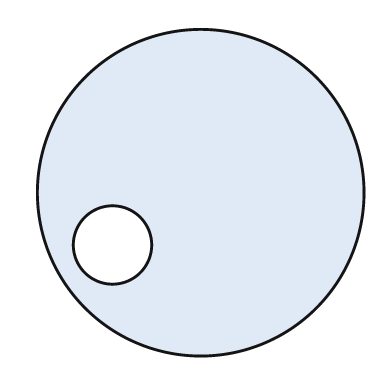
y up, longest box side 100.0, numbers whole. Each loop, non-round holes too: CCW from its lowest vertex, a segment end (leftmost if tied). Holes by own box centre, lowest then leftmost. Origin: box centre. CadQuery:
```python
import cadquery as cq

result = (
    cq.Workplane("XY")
    .moveTo(0.0, 0.0)
    .circle(50.0)
    .moveTo(-27.0, -16.0)
    .circle(12.0)
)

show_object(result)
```